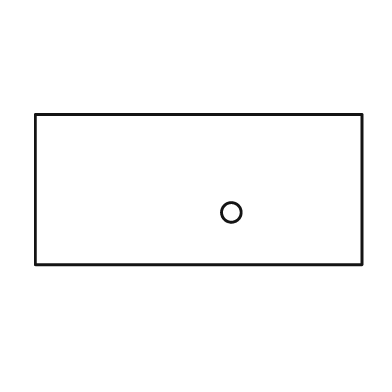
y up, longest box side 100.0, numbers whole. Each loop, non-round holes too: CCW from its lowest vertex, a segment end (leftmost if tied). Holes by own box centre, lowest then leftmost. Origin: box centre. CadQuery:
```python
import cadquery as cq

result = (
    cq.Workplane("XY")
    .moveTo(-50.0, -23.0)
    .lineTo(50.0, -23.0)
    .lineTo(50.0, 23.0)
    .lineTo(-50.0, 23.0)
    .close()
    .moveTo(10.0, -7.0)
    .circle(3.0)
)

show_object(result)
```